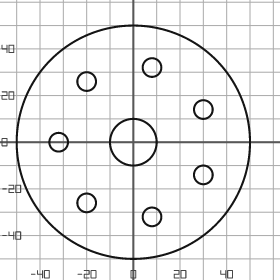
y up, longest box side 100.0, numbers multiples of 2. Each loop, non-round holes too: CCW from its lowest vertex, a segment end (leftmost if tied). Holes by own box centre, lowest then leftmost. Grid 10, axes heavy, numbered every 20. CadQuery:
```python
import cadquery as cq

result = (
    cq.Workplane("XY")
    .moveTo(0.0, 0.0)
    .circle(50.0)
    .moveTo(8.0, -32.0)
    .circle(4.0)
    .moveTo(-20.0, -26.0)
    .circle(4.0)
    .moveTo(30.0, -14.0)
    .circle(4.0)
    .moveTo(-32.0, 0.0)
    .circle(4.0)
    .moveTo(0.0, 0.0)
    .circle(10.0)
    .moveTo(30.0, 14.0)
    .circle(4.0)
    .moveTo(-20.0, 26.0)
    .circle(4.0)
    .moveTo(8.0, 32.0)
    .circle(4.0)
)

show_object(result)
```